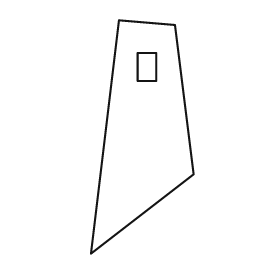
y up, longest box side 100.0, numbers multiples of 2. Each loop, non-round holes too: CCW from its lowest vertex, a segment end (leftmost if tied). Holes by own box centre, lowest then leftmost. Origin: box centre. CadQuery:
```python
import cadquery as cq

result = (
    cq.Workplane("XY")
    .moveTo(-22.0, -50.0)
    .lineTo(22.0, -16.0)
    .lineTo(14.0, 48.0)
    .lineTo(-10.0, 50.0)
    .close()
    .moveTo(-2.0, 24.0)
    .lineTo(6.0, 24.0)
    .lineTo(6.0, 36.0)
    .lineTo(-2.0, 36.0)
    .close()
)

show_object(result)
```